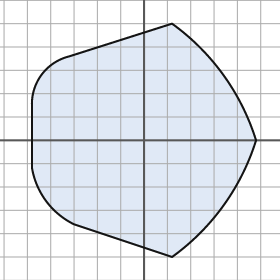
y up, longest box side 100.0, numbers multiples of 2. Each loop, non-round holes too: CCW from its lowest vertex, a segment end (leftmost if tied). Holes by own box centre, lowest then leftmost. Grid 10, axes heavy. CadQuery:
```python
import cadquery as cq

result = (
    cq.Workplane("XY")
    .moveTo(12.0, -50.0)
    .threePointArc((34.0, -28.0), (48.0, 0.0))
    .threePointArc((34.0, 28.0), (12.0, 50.0))
    .lineTo(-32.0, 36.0)
    .threePointArc((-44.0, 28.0), (-48.0, 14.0))
    .lineTo(-48.0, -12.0)
    .threePointArc((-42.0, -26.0), (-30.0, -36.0))
    .close()
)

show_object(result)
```